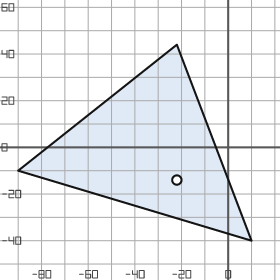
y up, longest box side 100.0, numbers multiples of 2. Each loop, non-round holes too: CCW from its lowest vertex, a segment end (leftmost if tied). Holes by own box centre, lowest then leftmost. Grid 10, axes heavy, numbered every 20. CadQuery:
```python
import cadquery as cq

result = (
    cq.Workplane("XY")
    .moveTo(10.0, -40.0)
    .lineTo(-22.0, 44.0)
    .lineTo(-90.0, -10.0)
    .close()
    .moveTo(-22.0, -14.0)
    .circle(2.0)
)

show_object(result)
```